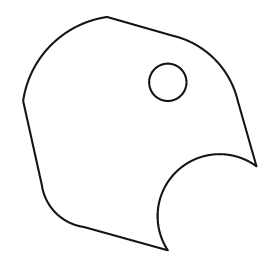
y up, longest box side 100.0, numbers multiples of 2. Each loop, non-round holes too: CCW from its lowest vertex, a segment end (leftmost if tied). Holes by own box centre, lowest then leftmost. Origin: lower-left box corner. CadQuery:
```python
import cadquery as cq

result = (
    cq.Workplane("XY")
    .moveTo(62.0, 0.0)
    .threePointArc((66.0, 34.0), (100.0, 36.0))
    .lineTo(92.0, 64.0)
    .threePointArc((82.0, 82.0), (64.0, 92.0))
    .lineTo(36.0, 100.0)
    .threePointArc((12.0, 88.0), (0.0, 64.0))
    .lineTo(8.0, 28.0)
    .threePointArc((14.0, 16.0), (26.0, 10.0))
    .close()
    .moveTo(62.0, 72.0)
    .circle(8.0)
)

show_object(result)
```